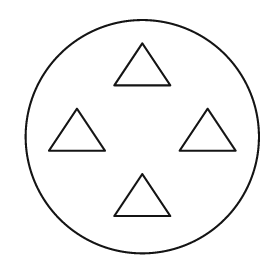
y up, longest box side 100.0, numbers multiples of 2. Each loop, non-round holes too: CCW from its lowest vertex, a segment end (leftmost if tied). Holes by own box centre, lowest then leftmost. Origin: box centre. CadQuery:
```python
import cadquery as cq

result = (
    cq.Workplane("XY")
    .moveTo(0.0, 0.0)
    .circle(50.0)
    .moveTo(-12.0, -34.0)
    .lineTo(12.0, -34.0)
    .lineTo(0.0, -16.0)
    .close()
    .moveTo(-40.0, -6.0)
    .lineTo(-16.0, -6.0)
    .lineTo(-28.0, 12.0)
    .close()
    .moveTo(16.0, -6.0)
    .lineTo(40.0, -6.0)
    .lineTo(28.0, 12.0)
    .close()
    .moveTo(-12.0, 22.0)
    .lineTo(12.0, 22.0)
    .lineTo(0.0, 40.0)
    .close()
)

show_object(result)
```